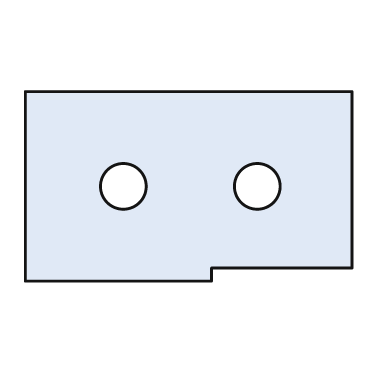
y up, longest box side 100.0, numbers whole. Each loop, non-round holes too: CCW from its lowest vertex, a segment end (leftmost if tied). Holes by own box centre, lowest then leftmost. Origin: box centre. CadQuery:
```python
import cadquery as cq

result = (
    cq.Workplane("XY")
    .moveTo(-50.0, -29.0)
    .lineTo(7.0, -29.0)
    .lineTo(7.0, -25.0)
    .lineTo(50.0, -25.0)
    .lineTo(50.0, 29.0)
    .lineTo(-50.0, 29.0)
    .close()
    .moveTo(-20.0, 0.0)
    .circle(7.0)
    .moveTo(21.0, 0.0)
    .circle(7.0)
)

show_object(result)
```